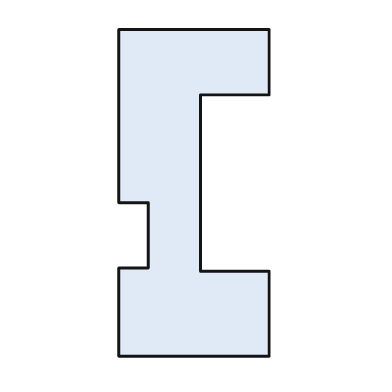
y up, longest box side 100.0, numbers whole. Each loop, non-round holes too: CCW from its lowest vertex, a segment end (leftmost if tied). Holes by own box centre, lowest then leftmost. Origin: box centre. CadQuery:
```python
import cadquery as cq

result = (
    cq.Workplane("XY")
    .moveTo(-23.0, -50.0)
    .lineTo(23.0, -50.0)
    .lineTo(23.0, -24.0)
    .lineTo(2.0, -24.0)
    .lineTo(2.0, 30.0)
    .lineTo(23.0, 30.0)
    .lineTo(23.0, 50.0)
    .lineTo(-23.0, 50.0)
    .lineTo(-23.0, -3.0)
    .lineTo(-14.0, -3.0)
    .lineTo(-14.0, -23.0)
    .lineTo(-23.0, -23.0)
    .close()
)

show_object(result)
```